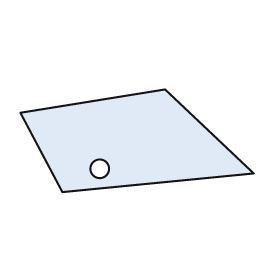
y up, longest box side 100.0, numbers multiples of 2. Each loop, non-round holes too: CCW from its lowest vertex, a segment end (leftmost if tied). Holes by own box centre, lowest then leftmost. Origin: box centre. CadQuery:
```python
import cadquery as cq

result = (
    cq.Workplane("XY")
    .moveTo(-32.0, -22.0)
    .lineTo(50.0, -14.0)
    .lineTo(12.0, 22.0)
    .lineTo(-50.0, 12.0)
    .close()
    .moveTo(-16.0, -12.0)
    .circle(4.0)
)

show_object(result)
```